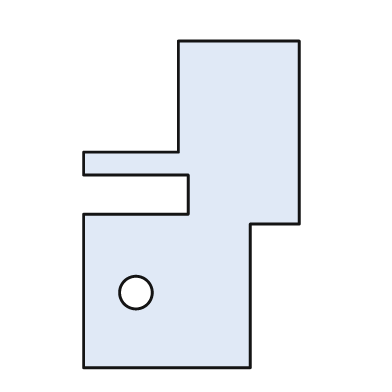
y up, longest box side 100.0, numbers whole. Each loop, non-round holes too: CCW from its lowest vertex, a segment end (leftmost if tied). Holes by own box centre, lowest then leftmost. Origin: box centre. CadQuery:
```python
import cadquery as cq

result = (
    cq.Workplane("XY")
    .moveTo(-33.0, -50.0)
    .lineTo(18.0, -50.0)
    .lineTo(18.0, -6.0)
    .lineTo(33.0, -6.0)
    .lineTo(33.0, 50.0)
    .lineTo(-4.0, 50.0)
    .lineTo(-4.0, 16.0)
    .lineTo(-33.0, 16.0)
    .lineTo(-33.0, 9.0)
    .lineTo(-1.0, 9.0)
    .lineTo(-1.0, -3.0)
    .lineTo(-33.0, -3.0)
    .close()
    .moveTo(-17.0, -27.0)
    .circle(5.0)
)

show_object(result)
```